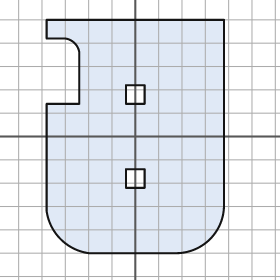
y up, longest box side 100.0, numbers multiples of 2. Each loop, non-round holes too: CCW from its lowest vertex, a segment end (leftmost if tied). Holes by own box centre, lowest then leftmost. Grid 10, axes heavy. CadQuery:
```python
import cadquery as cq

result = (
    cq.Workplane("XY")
    .moveTo(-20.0, -50.0)
    .lineTo(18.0, -50.0)
    .threePointArc((32.0, -44.0), (38.0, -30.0))
    .lineTo(38.0, 50.0)
    .lineTo(-38.0, 50.0)
    .lineTo(-38.0, 42.0)
    .lineTo(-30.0, 42.0)
    .threePointArc((-26.0, 40.0), (-24.0, 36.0))
    .lineTo(-24.0, 14.0)
    .lineTo(-38.0, 14.0)
    .lineTo(-38.0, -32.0)
    .threePointArc((-32.0, -44.0), (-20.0, -50.0))
    .close()
    .moveTo(-4.0, -22.0)
    .lineTo(4.0, -22.0)
    .lineTo(4.0, -14.0)
    .lineTo(-4.0, -14.0)
    .close()
    .moveTo(-4.0, 14.0)
    .lineTo(4.0, 14.0)
    .lineTo(4.0, 22.0)
    .lineTo(-4.0, 22.0)
    .close()
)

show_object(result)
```